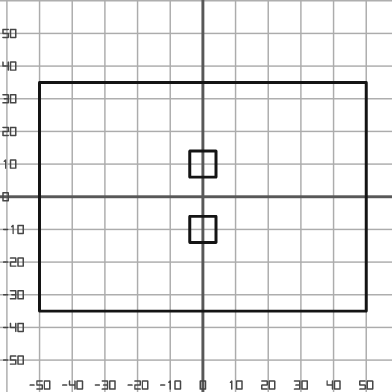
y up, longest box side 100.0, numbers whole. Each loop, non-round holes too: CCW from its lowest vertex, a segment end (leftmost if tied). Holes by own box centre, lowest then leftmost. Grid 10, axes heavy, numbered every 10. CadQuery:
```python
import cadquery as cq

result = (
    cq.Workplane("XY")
    .moveTo(-50.0, -35.0)
    .lineTo(50.0, -35.0)
    .lineTo(50.0, 35.0)
    .lineTo(-50.0, 35.0)
    .close()
    .moveTo(-4.0, -14.0)
    .lineTo(4.0, -14.0)
    .lineTo(4.0, -6.0)
    .lineTo(-4.0, -6.0)
    .close()
    .moveTo(-4.0, 6.0)
    .lineTo(4.0, 6.0)
    .lineTo(4.0, 14.0)
    .lineTo(-4.0, 14.0)
    .close()
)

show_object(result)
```